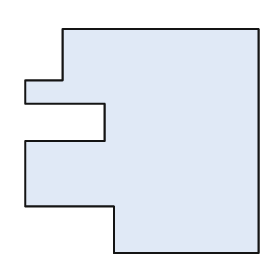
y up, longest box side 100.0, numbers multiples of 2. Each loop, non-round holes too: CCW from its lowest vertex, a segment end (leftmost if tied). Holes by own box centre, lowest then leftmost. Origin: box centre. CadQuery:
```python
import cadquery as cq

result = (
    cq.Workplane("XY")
    .moveTo(-12.0, -48.0)
    .lineTo(50.0, -48.0)
    .lineTo(50.0, 48.0)
    .lineTo(-34.0, 48.0)
    .lineTo(-34.0, 26.0)
    .lineTo(-50.0, 26.0)
    .lineTo(-50.0, 16.0)
    .lineTo(-16.0, 16.0)
    .lineTo(-16.0, 0.0)
    .lineTo(-50.0, 0.0)
    .lineTo(-50.0, -28.0)
    .lineTo(-12.0, -28.0)
    .close()
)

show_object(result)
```